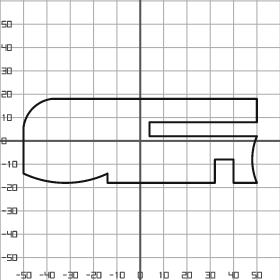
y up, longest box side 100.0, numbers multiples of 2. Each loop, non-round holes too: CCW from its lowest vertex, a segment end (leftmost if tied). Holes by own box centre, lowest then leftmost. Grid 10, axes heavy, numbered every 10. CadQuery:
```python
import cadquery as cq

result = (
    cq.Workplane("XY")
    .moveTo(-14.0, -18.0)
    .lineTo(32.0, -18.0)
    .lineTo(32.0, -8.0)
    .lineTo(40.0, -8.0)
    .lineTo(40.0, -18.0)
    .lineTo(50.0, -18.0)
    .threePointArc((48.0, -8.0), (50.0, 2.0))
    .lineTo(4.0, 2.0)
    .lineTo(4.0, 8.0)
    .lineTo(50.0, 8.0)
    .lineTo(50.0, 18.0)
    .lineTo(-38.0, 18.0)
    .threePointArc((-46.0, 14.0), (-50.0, 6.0))
    .lineTo(-50.0, -14.0)
    .threePointArc((-32.0, -18.0), (-14.0, -14.0))
    .close()
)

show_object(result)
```